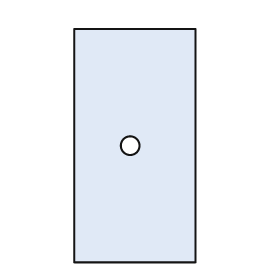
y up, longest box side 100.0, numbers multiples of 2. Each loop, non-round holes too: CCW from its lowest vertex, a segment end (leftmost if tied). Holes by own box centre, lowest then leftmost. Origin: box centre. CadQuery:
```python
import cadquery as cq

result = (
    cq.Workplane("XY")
    .moveTo(-26.0, -50.0)
    .lineTo(26.0, -50.0)
    .lineTo(26.0, 50.0)
    .lineTo(-26.0, 50.0)
    .close()
    .moveTo(-2.0, 0.0)
    .circle(4.0)
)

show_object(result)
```